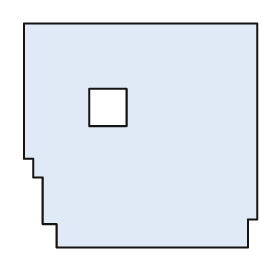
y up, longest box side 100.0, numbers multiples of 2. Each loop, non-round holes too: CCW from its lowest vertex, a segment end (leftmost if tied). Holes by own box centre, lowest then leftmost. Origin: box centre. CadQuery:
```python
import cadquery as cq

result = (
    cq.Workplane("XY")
    .moveTo(-36.0, -48.0)
    .lineTo(46.0, -48.0)
    .lineTo(46.0, -36.0)
    .lineTo(50.0, -36.0)
    .lineTo(50.0, 48.0)
    .lineTo(-50.0, 48.0)
    .lineTo(-50.0, -10.0)
    .lineTo(-46.0, -10.0)
    .lineTo(-46.0, -18.0)
    .lineTo(-42.0, -18.0)
    .lineTo(-42.0, -38.0)
    .lineTo(-36.0, -38.0)
    .close()
    .moveTo(-22.0, 4.0)
    .lineTo(-6.0, 4.0)
    .lineTo(-6.0, 20.0)
    .lineTo(-22.0, 20.0)
    .close()
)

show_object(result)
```